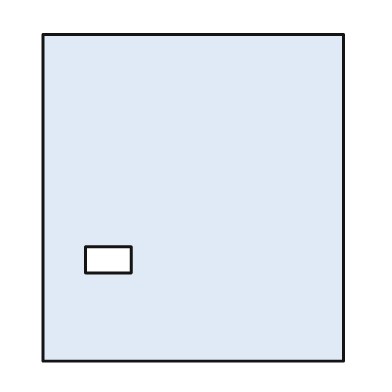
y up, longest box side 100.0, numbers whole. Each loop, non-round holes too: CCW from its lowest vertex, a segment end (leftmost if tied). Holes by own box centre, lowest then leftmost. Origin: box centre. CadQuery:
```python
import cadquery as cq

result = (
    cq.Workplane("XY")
    .moveTo(-46.0, -50.0)
    .lineTo(46.0, -50.0)
    .lineTo(46.0, 50.0)
    .lineTo(-46.0, 50.0)
    .close()
    .moveTo(-33.0, -23.0)
    .lineTo(-19.0, -23.0)
    .lineTo(-19.0, -15.0)
    .lineTo(-33.0, -15.0)
    .close()
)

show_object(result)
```